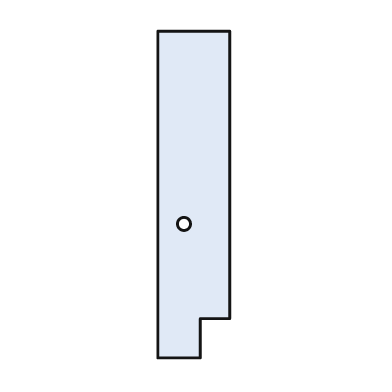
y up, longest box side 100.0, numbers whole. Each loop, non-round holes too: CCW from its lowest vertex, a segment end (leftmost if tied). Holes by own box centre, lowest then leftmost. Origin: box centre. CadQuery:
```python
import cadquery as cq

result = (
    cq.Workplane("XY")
    .moveTo(-11.0, -50.0)
    .lineTo(2.0, -50.0)
    .lineTo(2.0, -38.0)
    .lineTo(11.0, -38.0)
    .lineTo(11.0, 50.0)
    .lineTo(-11.0, 50.0)
    .close()
    .moveTo(-3.0, -9.0)
    .circle(2.0)
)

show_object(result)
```